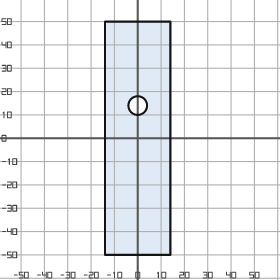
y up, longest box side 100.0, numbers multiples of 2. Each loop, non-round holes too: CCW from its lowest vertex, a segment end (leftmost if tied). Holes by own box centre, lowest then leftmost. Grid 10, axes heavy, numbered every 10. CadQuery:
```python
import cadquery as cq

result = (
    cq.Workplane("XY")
    .moveTo(-14.0, -50.0)
    .lineTo(14.0, -50.0)
    .lineTo(14.0, 50.0)
    .lineTo(-14.0, 50.0)
    .close()
    .moveTo(0.0, 14.0)
    .circle(4.0)
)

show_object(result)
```